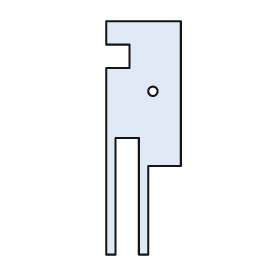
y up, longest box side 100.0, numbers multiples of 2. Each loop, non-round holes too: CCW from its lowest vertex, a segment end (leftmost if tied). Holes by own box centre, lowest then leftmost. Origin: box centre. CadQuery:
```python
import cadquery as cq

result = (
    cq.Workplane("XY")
    .moveTo(-16.0, -50.0)
    .lineTo(-12.0, -50.0)
    .lineTo(-12.0, 0.0)
    .lineTo(-2.0, 0.0)
    .lineTo(-2.0, -50.0)
    .lineTo(2.0, -50.0)
    .lineTo(2.0, -12.0)
    .lineTo(16.0, -12.0)
    .lineTo(16.0, 50.0)
    .lineTo(-16.0, 50.0)
    .lineTo(-16.0, 40.0)
    .lineTo(-6.0, 40.0)
    .lineTo(-6.0, 30.0)
    .lineTo(-16.0, 30.0)
    .close()
    .moveTo(4.0, 20.0)
    .circle(2.0)
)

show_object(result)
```